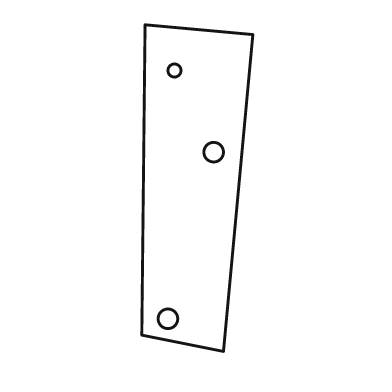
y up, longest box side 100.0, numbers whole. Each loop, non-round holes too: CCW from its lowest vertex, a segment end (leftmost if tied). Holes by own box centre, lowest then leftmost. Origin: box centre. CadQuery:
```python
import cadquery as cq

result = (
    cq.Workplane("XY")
    .moveTo(8.0, -50.0)
    .lineTo(17.0, 47.0)
    .lineTo(-16.0, 50.0)
    .lineTo(-17.0, -45.0)
    .close()
    .moveTo(-9.0, -40.0)
    .circle(3.0)
    .moveTo(5.0, 11.0)
    .circle(3.0)
    .moveTo(-7.0, 36.0)
    .circle(2.0)
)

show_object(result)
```